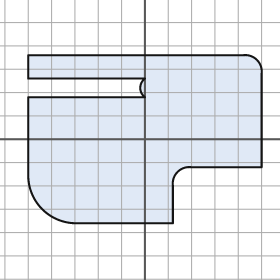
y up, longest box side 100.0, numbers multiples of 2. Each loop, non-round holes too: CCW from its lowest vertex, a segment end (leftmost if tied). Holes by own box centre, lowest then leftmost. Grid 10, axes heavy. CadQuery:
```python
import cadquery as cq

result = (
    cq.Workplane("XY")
    .moveTo(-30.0, -36.0)
    .lineTo(12.0, -36.0)
    .lineTo(12.0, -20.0)
    .threePointArc((14.0, -14.0), (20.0, -12.0))
    .lineTo(50.0, -12.0)
    .lineTo(50.0, 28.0)
    .threePointArc((48.0, 34.0), (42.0, 36.0))
    .lineTo(-50.0, 36.0)
    .lineTo(-50.0, 26.0)
    .lineTo(0.0, 26.0)
    .threePointArc((-2.0, 22.0), (0.0, 18.0))
    .lineTo(-50.0, 18.0)
    .lineTo(-50.0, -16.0)
    .threePointArc((-44.0, -30.0), (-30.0, -36.0))
    .close()
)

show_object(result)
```